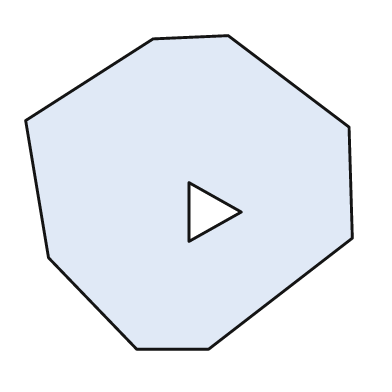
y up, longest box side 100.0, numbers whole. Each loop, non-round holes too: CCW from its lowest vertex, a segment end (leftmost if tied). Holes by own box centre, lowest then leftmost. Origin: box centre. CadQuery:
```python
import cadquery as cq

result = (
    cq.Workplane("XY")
    .moveTo(-16.0, -48.0)
    .lineTo(6.0, -48.0)
    .lineTo(50.0, -14.0)
    .lineTo(49.0, 20.0)
    .lineTo(12.0, 48.0)
    .lineTo(-11.0, 47.0)
    .lineTo(-50.0, 22.0)
    .lineTo(-43.0, -20.0)
    .close()
    .moveTo(0.0, -15.0)
    .lineTo(16.0, -6.0)
    .lineTo(0.0, 3.0)
    .close()
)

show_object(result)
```